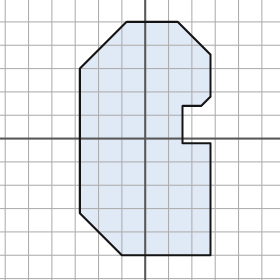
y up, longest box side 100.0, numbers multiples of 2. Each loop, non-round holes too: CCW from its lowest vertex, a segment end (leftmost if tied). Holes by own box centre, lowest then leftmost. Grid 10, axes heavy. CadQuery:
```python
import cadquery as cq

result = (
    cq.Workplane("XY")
    .moveTo(-10.0, -50.0)
    .lineTo(28.0, -50.0)
    .lineTo(28.0, -2.0)
    .lineTo(16.0, -2.0)
    .lineTo(16.0, 14.0)
    .lineTo(24.0, 14.0)
    .lineTo(28.0, 18.0)
    .lineTo(28.0, 36.0)
    .lineTo(14.0, 50.0)
    .lineTo(-8.0, 50.0)
    .lineTo(-28.0, 30.0)
    .lineTo(-28.0, -32.0)
    .close()
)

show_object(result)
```